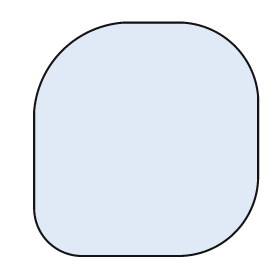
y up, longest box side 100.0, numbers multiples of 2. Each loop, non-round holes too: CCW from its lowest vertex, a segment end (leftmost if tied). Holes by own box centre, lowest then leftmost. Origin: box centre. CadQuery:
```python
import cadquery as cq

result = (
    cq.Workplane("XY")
    .moveTo(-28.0, -50.0)
    .lineTo(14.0, -50.0)
    .threePointArc((38.0, -40.0), (48.0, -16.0))
    .lineTo(48.0, 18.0)
    .threePointArc((38.0, 40.0), (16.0, 50.0))
    .lineTo(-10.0, 50.0)
    .threePointArc((-36.0, 38.0), (-48.0, 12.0))
    .lineTo(-48.0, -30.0)
    .threePointArc((-42.0, -44.0), (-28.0, -50.0))
    .close()
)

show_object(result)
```